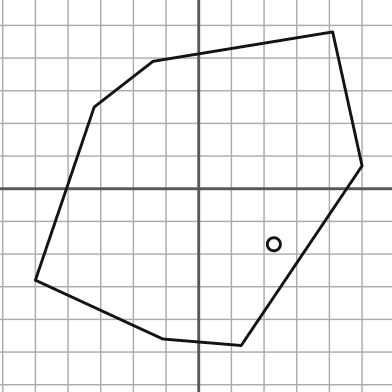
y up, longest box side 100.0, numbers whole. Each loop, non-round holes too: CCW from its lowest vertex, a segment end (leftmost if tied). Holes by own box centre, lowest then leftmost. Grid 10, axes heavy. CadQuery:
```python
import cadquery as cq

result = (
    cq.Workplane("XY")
    .moveTo(13.0, -48.0)
    .lineTo(50.0, 7.0)
    .lineTo(41.0, 48.0)
    .lineTo(-14.0, 39.0)
    .lineTo(-32.0, 25.0)
    .lineTo(-50.0, -28.0)
    .lineTo(-11.0, -46.0)
    .close()
    .moveTo(23.0, -17.0)
    .circle(2.0)
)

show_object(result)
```